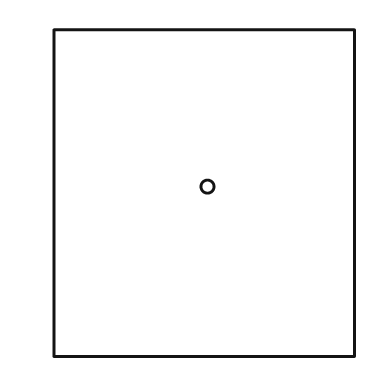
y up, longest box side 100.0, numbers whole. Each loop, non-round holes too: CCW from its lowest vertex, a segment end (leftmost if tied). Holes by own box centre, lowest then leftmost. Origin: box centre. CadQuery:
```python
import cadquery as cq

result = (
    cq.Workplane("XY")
    .moveTo(-46.0, -50.0)
    .lineTo(46.0, -50.0)
    .lineTo(46.0, 50.0)
    .lineTo(-46.0, 50.0)
    .close()
    .moveTo(1.0, 2.0)
    .circle(2.0)
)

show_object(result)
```